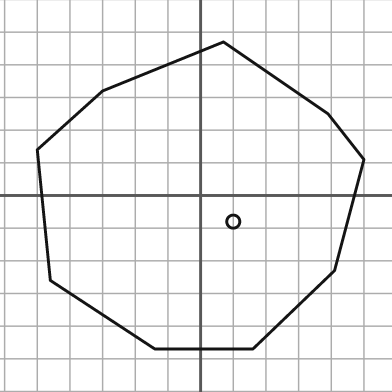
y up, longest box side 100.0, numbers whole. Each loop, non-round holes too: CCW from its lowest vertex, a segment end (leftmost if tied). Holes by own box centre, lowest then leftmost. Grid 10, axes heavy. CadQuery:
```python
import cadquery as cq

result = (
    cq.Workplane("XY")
    .moveTo(-14.0, -47.0)
    .lineTo(16.0, -47.0)
    .lineTo(41.0, -23.0)
    .lineTo(50.0, 11.0)
    .lineTo(39.0, 25.0)
    .lineTo(7.0, 47.0)
    .lineTo(-30.0, 32.0)
    .lineTo(-50.0, 14.0)
    .lineTo(-46.0, -26.0)
    .close()
    .moveTo(10.0, -8.0)
    .circle(2.0)
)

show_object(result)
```